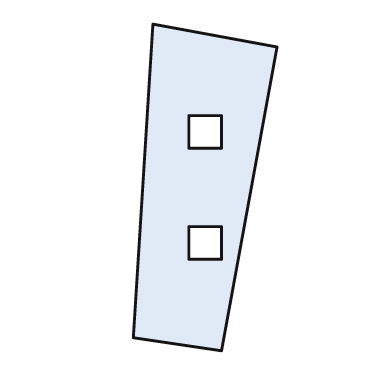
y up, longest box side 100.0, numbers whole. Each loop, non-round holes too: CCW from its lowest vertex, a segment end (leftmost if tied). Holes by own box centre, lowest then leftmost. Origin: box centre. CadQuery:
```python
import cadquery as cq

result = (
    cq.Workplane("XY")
    .moveTo(5.0, -50.0)
    .lineTo(22.0, 43.0)
    .lineTo(-16.0, 50.0)
    .lineTo(-22.0, -46.0)
    .close()
    .moveTo(-5.0, -22.0)
    .lineTo(5.0, -22.0)
    .lineTo(5.0, -12.0)
    .lineTo(-5.0, -12.0)
    .close()
    .moveTo(-5.0, 12.0)
    .lineTo(5.0, 12.0)
    .lineTo(5.0, 22.0)
    .lineTo(-5.0, 22.0)
    .close()
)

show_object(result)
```